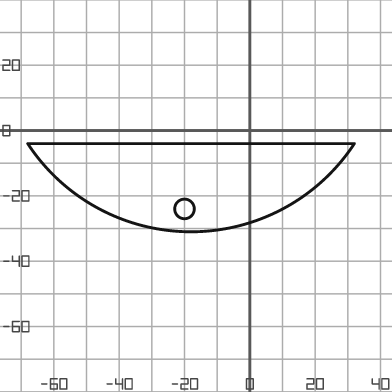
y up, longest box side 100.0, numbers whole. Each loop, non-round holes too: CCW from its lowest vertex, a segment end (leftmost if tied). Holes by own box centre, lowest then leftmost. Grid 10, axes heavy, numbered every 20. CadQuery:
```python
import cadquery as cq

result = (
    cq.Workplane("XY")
    .moveTo(-68.0, -4.0)
    .threePointArc((-18.0, -31.0), (32.0, -4.0))
    .close()
    .moveTo(-20.0, -24.0)
    .circle(3.0)
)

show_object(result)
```